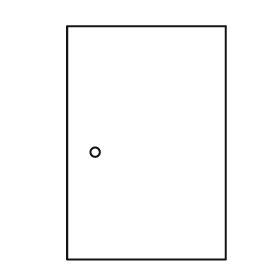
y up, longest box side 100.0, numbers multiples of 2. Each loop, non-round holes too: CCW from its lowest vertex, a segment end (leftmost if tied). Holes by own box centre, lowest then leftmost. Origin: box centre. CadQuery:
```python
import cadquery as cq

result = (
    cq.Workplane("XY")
    .moveTo(-34.0, -50.0)
    .lineTo(34.0, -50.0)
    .lineTo(34.0, 50.0)
    .lineTo(-34.0, 50.0)
    .close()
    .moveTo(-22.0, -4.0)
    .circle(2.0)
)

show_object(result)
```